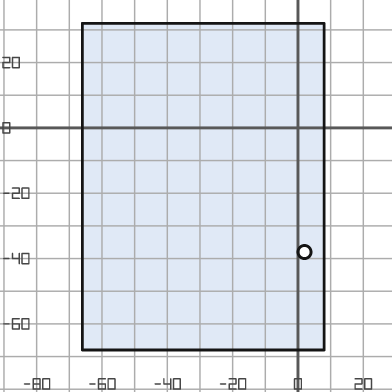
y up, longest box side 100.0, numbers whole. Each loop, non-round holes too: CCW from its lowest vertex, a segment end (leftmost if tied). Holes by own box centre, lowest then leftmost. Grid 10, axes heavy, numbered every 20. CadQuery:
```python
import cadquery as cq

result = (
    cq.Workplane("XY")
    .moveTo(-66.0, -68.0)
    .lineTo(8.0, -68.0)
    .lineTo(8.0, 32.0)
    .lineTo(-66.0, 32.0)
    .close()
    .moveTo(2.0, -38.0)
    .circle(2.0)
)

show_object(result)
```